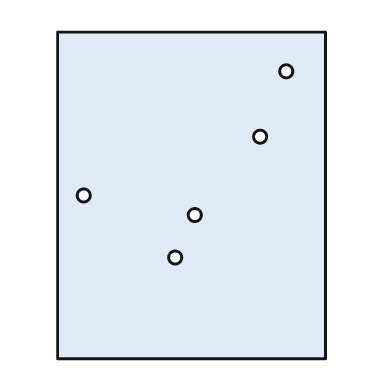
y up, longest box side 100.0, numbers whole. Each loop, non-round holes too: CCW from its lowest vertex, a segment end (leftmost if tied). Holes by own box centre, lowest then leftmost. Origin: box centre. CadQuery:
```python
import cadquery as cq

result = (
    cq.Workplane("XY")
    .moveTo(-41.0, -50.0)
    .lineTo(41.0, -50.0)
    .lineTo(41.0, 50.0)
    .lineTo(-41.0, 50.0)
    .close()
    .moveTo(-5.0, -19.0)
    .circle(2.0)
    .moveTo(1.0, -6.0)
    .circle(2.0)
    .moveTo(-33.0, 0.0)
    .circle(2.0)
    .moveTo(21.0, 18.0)
    .circle(2.0)
    .moveTo(29.0, 38.0)
    .circle(2.0)
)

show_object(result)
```